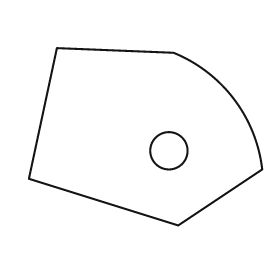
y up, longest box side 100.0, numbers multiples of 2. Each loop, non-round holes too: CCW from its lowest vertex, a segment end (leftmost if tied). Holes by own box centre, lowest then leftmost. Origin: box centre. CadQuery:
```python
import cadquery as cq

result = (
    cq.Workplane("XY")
    .moveTo(14.0, -38.0)
    .lineTo(50.0, -14.0)
    .threePointArc((38.0, 16.0), (12.0, 36.0))
    .lineTo(-38.0, 38.0)
    .lineTo(-50.0, -18.0)
    .close()
    .moveTo(10.0, -6.0)
    .circle(8.0)
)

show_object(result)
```